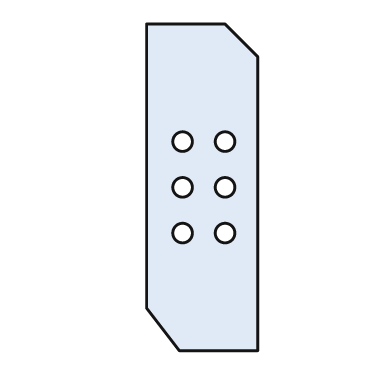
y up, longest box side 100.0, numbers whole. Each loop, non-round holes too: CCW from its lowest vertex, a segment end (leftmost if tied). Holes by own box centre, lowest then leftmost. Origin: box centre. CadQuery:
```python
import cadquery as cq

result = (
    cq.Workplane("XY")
    .moveTo(-7.0, -50.0)
    .lineTo(17.0, -50.0)
    .lineTo(17.0, 40.0)
    .lineTo(7.0, 50.0)
    .lineTo(-17.0, 50.0)
    .lineTo(-17.0, -37.0)
    .close()
    .moveTo(-6.0, -14.0)
    .circle(3.0)
    .moveTo(7.0, -14.0)
    .circle(3.0)
    .moveTo(-6.0, 0.0)
    .circle(3.0)
    .moveTo(7.0, 0.0)
    .circle(3.0)
    .moveTo(-6.0, 14.0)
    .circle(3.0)
    .moveTo(7.0, 14.0)
    .circle(3.0)
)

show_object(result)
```